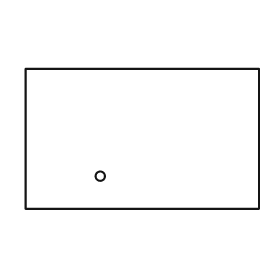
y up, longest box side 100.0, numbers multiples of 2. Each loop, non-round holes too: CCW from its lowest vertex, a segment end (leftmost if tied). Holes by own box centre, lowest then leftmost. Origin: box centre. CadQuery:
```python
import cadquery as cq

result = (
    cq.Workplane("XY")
    .moveTo(-50.0, -30.0)
    .lineTo(50.0, -30.0)
    .lineTo(50.0, 30.0)
    .lineTo(-50.0, 30.0)
    .close()
    .moveTo(-18.0, -16.0)
    .circle(2.0)
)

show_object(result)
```